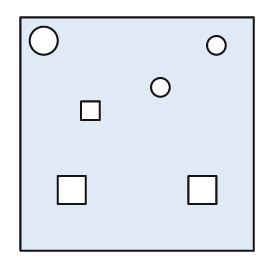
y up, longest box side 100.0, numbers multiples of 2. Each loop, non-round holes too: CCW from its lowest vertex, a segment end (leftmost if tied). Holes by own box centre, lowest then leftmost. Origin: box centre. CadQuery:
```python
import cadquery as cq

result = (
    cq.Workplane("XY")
    .moveTo(-50.0, -50.0)
    .lineTo(50.0, -50.0)
    .lineTo(50.0, 50.0)
    .lineTo(-50.0, 50.0)
    .close()
    .moveTo(-34.0, -30.0)
    .lineTo(-22.0, -30.0)
    .lineTo(-22.0, -18.0)
    .lineTo(-34.0, -18.0)
    .close()
    .moveTo(22.0, -30.0)
    .lineTo(34.0, -30.0)
    .lineTo(34.0, -18.0)
    .lineTo(22.0, -18.0)
    .close()
    .moveTo(-24.0, 6.0)
    .lineTo(-16.0, 6.0)
    .lineTo(-16.0, 14.0)
    .lineTo(-24.0, 14.0)
    .close()
    .moveTo(10.0, 20.0)
    .circle(4.0)
    .moveTo(34.0, 38.0)
    .circle(4.0)
    .moveTo(-40.0, 40.0)
    .circle(6.0)
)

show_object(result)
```